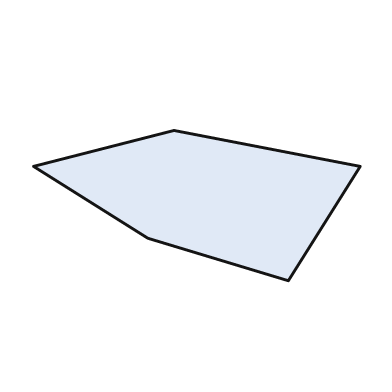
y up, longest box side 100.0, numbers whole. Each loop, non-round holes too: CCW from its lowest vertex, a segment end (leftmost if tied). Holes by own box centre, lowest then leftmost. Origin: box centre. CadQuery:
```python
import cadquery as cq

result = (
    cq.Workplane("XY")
    .moveTo(28.0, -23.0)
    .lineTo(50.0, 12.0)
    .lineTo(-7.0, 23.0)
    .lineTo(-50.0, 12.0)
    .lineTo(-15.0, -10.0)
    .close()
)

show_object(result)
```